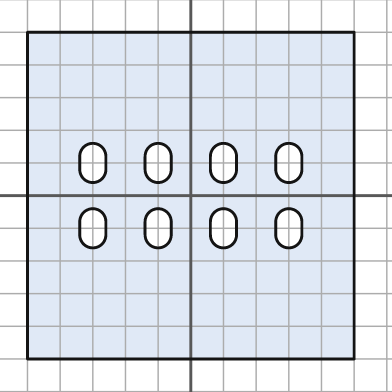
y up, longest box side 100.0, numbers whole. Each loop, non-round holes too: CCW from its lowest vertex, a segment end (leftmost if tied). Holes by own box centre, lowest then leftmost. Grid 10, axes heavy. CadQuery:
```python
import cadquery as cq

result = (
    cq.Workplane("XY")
    .moveTo(-50.0, -50.0)
    .lineTo(50.0, -50.0)
    .lineTo(50.0, 50.0)
    .lineTo(-50.0, 50.0)
    .close()
    .moveTo(-34.0, -12.0)
    .threePointArc((-30.0, -16.0), (-26.0, -12.0))
    .lineTo(-26.0, -8.0)
    .threePointArc((-30.0, -4.0), (-34.0, -8.0))
    .close()
    .moveTo(-14.0, -12.0)
    .threePointArc((-10.0, -16.0), (-6.0, -12.0))
    .lineTo(-6.0, -8.0)
    .threePointArc((-10.0, -4.0), (-14.0, -8.0))
    .close()
    .moveTo(6.0, -12.0)
    .threePointArc((10.0, -16.0), (14.0, -12.0))
    .lineTo(14.0, -8.0)
    .threePointArc((10.0, -4.0), (6.0, -8.0))
    .close()
    .moveTo(26.0, -12.0)
    .threePointArc((30.0, -16.0), (34.0, -12.0))
    .lineTo(34.0, -8.0)
    .threePointArc((30.0, -4.0), (26.0, -8.0))
    .close()
    .moveTo(-34.0, 8.0)
    .threePointArc((-30.0, 4.0), (-26.0, 8.0))
    .lineTo(-26.0, 12.0)
    .threePointArc((-30.0, 16.0), (-34.0, 12.0))
    .close()
    .moveTo(-14.0, 8.0)
    .threePointArc((-10.0, 4.0), (-6.0, 8.0))
    .lineTo(-6.0, 12.0)
    .threePointArc((-10.0, 16.0), (-14.0, 12.0))
    .close()
    .moveTo(6.0, 8.0)
    .threePointArc((10.0, 4.0), (14.0, 8.0))
    .lineTo(14.0, 12.0)
    .threePointArc((10.0, 16.0), (6.0, 12.0))
    .close()
    .moveTo(26.0, 8.0)
    .threePointArc((30.0, 4.0), (34.0, 8.0))
    .lineTo(34.0, 12.0)
    .threePointArc((30.0, 16.0), (26.0, 12.0))
    .close()
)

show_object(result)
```